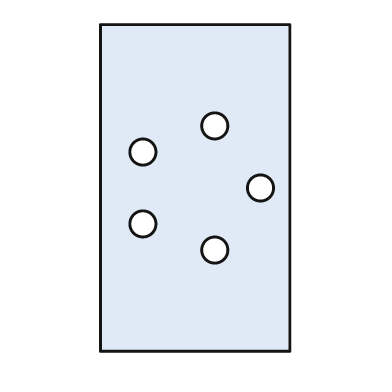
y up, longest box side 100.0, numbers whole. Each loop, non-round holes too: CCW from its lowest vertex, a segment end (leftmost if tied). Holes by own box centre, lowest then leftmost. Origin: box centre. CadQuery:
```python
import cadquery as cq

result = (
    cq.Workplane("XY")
    .moveTo(-29.0, -50.0)
    .lineTo(29.0, -50.0)
    .lineTo(29.0, 50.0)
    .lineTo(-29.0, 50.0)
    .close()
    .moveTo(6.0, -19.0)
    .circle(4.0)
    .moveTo(-16.0, -11.0)
    .circle(4.0)
    .moveTo(20.0, 0.0)
    .circle(4.0)
    .moveTo(-16.0, 11.0)
    .circle(4.0)
    .moveTo(6.0, 19.0)
    .circle(4.0)
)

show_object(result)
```